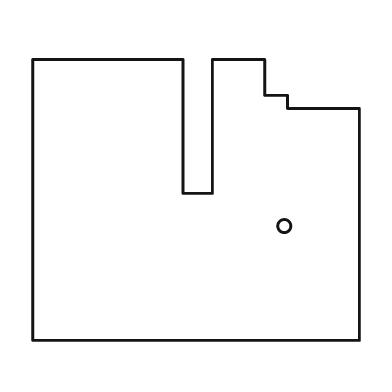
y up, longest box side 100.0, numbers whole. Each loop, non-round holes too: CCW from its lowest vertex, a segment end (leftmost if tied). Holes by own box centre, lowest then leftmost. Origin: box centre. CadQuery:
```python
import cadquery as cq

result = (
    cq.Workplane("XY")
    .moveTo(-50.0, -43.0)
    .lineTo(50.0, -43.0)
    .lineTo(50.0, 28.0)
    .lineTo(28.0, 28.0)
    .lineTo(28.0, 32.0)
    .lineTo(21.0, 32.0)
    .lineTo(21.0, 43.0)
    .lineTo(5.0, 43.0)
    .lineTo(5.0, 2.0)
    .lineTo(-4.0, 2.0)
    .lineTo(-4.0, 43.0)
    .lineTo(-50.0, 43.0)
    .close()
    .moveTo(27.0, -8.0)
    .circle(2.0)
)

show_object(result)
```